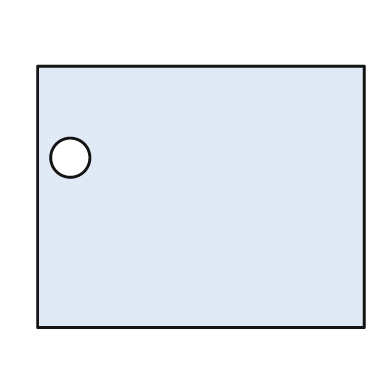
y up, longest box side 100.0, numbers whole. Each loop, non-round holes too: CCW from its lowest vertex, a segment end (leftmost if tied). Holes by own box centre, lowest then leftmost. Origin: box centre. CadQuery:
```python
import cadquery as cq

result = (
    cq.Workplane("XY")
    .moveTo(-50.0, -40.0)
    .lineTo(50.0, -40.0)
    .lineTo(50.0, 40.0)
    .lineTo(-50.0, 40.0)
    .close()
    .moveTo(-40.0, 12.0)
    .circle(6.0)
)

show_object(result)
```